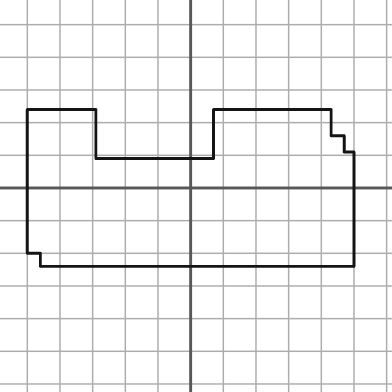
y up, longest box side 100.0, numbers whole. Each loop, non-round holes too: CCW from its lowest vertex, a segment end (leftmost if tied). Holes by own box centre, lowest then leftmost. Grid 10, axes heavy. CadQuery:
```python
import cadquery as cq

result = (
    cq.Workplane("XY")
    .moveTo(-46.0, -24.0)
    .lineTo(50.0, -24.0)
    .lineTo(50.0, 11.0)
    .lineTo(47.0, 11.0)
    .lineTo(47.0, 16.0)
    .lineTo(43.0, 16.0)
    .lineTo(43.0, 24.0)
    .lineTo(7.0, 24.0)
    .lineTo(7.0, 9.0)
    .lineTo(-29.0, 9.0)
    .lineTo(-29.0, 24.0)
    .lineTo(-50.0, 24.0)
    .lineTo(-50.0, -20.0)
    .lineTo(-46.0, -20.0)
    .close()
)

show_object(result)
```